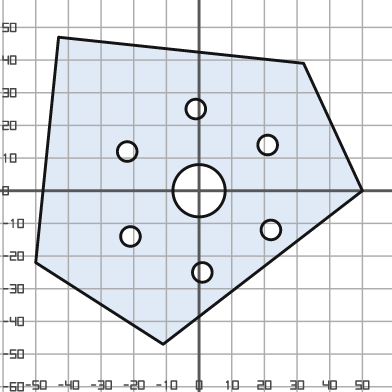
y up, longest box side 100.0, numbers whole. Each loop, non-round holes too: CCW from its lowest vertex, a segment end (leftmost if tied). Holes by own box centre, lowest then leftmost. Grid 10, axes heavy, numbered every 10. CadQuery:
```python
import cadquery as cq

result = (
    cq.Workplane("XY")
    .moveTo(-11.0, -47.0)
    .lineTo(50.0, 0.0)
    .lineTo(32.0, 39.0)
    .lineTo(-43.0, 47.0)
    .lineTo(-50.0, -22.0)
    .close()
    .moveTo(1.0, -25.0)
    .circle(3.0)
    .moveTo(-21.0, -14.0)
    .circle(3.0)
    .moveTo(22.0, -12.0)
    .circle(3.0)
    .moveTo(0.0, 0.0)
    .circle(8.0)
    .moveTo(-22.0, 12.0)
    .circle(3.0)
    .moveTo(21.0, 14.0)
    .circle(3.0)
    .moveTo(-1.0, 25.0)
    .circle(3.0)
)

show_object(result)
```